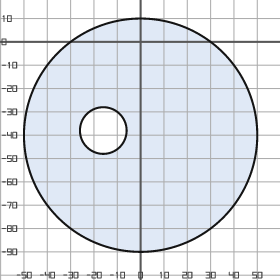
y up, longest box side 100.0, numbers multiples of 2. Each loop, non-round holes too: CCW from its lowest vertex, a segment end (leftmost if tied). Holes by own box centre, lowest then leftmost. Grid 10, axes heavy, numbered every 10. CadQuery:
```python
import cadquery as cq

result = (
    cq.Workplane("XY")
    .moveTo(0.0, -40.0)
    .circle(50.0)
    .moveTo(-16.0, -38.0)
    .circle(10.0)
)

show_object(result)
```